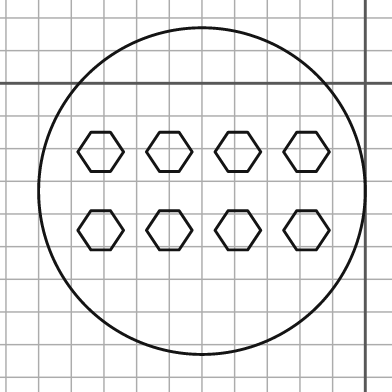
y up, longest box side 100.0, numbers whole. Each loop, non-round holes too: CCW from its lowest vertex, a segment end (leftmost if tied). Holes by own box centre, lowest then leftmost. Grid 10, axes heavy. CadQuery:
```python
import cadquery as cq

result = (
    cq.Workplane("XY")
    .moveTo(-50.0, -33.0)
    .circle(50.0)
    .moveTo(-84.0, -51.0)
    .lineTo(-78.0, -51.0)
    .lineTo(-74.0, -45.0)
    .lineTo(-78.0, -39.0)
    .lineTo(-84.0, -39.0)
    .lineTo(-88.0, -45.0)
    .close()
    .moveTo(-63.0, -51.0)
    .lineTo(-57.0, -51.0)
    .lineTo(-53.0, -45.0)
    .lineTo(-57.0, -39.0)
    .lineTo(-63.0, -39.0)
    .lineTo(-67.0, -45.0)
    .close()
    .moveTo(-42.0, -51.0)
    .lineTo(-36.0, -51.0)
    .lineTo(-32.0, -45.0)
    .lineTo(-36.0, -39.0)
    .lineTo(-42.0, -39.0)
    .lineTo(-46.0, -45.0)
    .close()
    .moveTo(-21.0, -51.0)
    .lineTo(-15.0, -51.0)
    .lineTo(-11.0, -45.0)
    .lineTo(-15.0, -39.0)
    .lineTo(-21.0, -39.0)
    .lineTo(-25.0, -45.0)
    .close()
    .moveTo(-84.0, -27.0)
    .lineTo(-78.0, -27.0)
    .lineTo(-74.0, -21.0)
    .lineTo(-78.0, -15.0)
    .lineTo(-84.0, -15.0)
    .lineTo(-88.0, -21.0)
    .close()
    .moveTo(-63.0, -27.0)
    .lineTo(-57.0, -27.0)
    .lineTo(-53.0, -21.0)
    .lineTo(-57.0, -15.0)
    .lineTo(-63.0, -15.0)
    .lineTo(-67.0, -21.0)
    .close()
    .moveTo(-42.0, -27.0)
    .lineTo(-36.0, -27.0)
    .lineTo(-32.0, -21.0)
    .lineTo(-36.0, -15.0)
    .lineTo(-42.0, -15.0)
    .lineTo(-46.0, -21.0)
    .close()
    .moveTo(-21.0, -27.0)
    .lineTo(-15.0, -27.0)
    .lineTo(-11.0, -21.0)
    .lineTo(-15.0, -15.0)
    .lineTo(-21.0, -15.0)
    .lineTo(-25.0, -21.0)
    .close()
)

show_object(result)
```